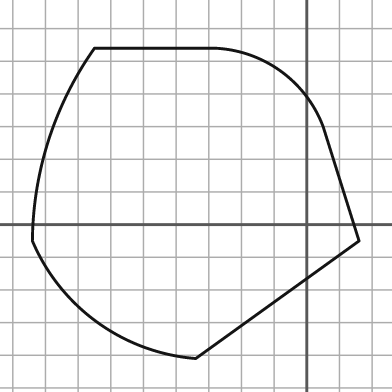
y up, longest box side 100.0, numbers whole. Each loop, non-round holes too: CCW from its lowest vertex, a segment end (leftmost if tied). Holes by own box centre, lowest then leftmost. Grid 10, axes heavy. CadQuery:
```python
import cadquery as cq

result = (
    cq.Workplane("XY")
    .moveTo(-34.0, -41.0)
    .lineTo(16.0, -5.0)
    .lineTo(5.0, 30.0)
    .threePointArc((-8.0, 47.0), (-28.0, 54.0))
    .lineTo(-65.0, 54.0)
    .threePointArc((-79.0, 26.0), (-84.0, -5.0))
    .threePointArc((-64.0, -30.0), (-34.0, -41.0))
    .close()
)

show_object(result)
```